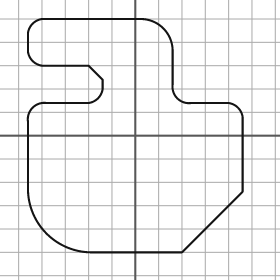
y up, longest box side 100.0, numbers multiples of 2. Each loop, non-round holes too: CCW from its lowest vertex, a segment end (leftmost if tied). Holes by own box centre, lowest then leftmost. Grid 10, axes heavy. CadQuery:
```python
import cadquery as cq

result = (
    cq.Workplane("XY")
    .moveTo(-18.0, -50.0)
    .lineTo(20.0, -50.0)
    .lineTo(46.0, -24.0)
    .lineTo(46.0, 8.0)
    .threePointArc((44.0, 12.0), (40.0, 14.0))
    .lineTo(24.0, 14.0)
    .threePointArc((18.0, 16.0), (16.0, 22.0))
    .lineTo(16.0, 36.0)
    .threePointArc((12.0, 46.0), (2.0, 50.0))
    .lineTo(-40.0, 50.0)
    .threePointArc((-44.0, 48.0), (-46.0, 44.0))
    .lineTo(-46.0, 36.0)
    .threePointArc((-44.0, 32.0), (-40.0, 30.0))
    .lineTo(-20.0, 30.0)
    .lineTo(-14.0, 24.0)
    .lineTo(-14.0, 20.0)
    .threePointArc((-16.0, 16.0), (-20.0, 14.0))
    .lineTo(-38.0, 14.0)
    .threePointArc((-44.0, 12.0), (-46.0, 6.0))
    .lineTo(-46.0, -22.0)
    .threePointArc((-38.0, -42.0), (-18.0, -50.0))
    .close()
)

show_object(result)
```